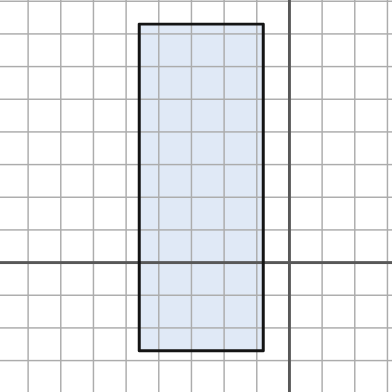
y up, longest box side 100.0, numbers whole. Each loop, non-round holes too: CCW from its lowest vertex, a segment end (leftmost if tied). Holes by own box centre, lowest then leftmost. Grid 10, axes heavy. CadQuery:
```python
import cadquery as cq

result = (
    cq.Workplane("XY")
    .moveTo(-46.0, -27.0)
    .lineTo(-8.0, -27.0)
    .lineTo(-8.0, 73.0)
    .lineTo(-46.0, 73.0)
    .close()
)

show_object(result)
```